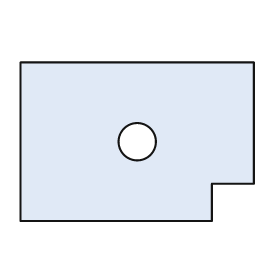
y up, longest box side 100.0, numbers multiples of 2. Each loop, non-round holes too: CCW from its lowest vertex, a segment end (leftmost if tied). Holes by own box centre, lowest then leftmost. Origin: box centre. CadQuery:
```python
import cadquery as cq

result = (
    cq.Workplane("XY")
    .moveTo(-50.0, -34.0)
    .lineTo(32.0, -34.0)
    .lineTo(32.0, -18.0)
    .lineTo(50.0, -18.0)
    .lineTo(50.0, 34.0)
    .lineTo(-50.0, 34.0)
    .close()
    .moveTo(0.0, 0.0)
    .circle(8.0)
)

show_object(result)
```